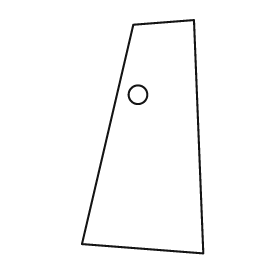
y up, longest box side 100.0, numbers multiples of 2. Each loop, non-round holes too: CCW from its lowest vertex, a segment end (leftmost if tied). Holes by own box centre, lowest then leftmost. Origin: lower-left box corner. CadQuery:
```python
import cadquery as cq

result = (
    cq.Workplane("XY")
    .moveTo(52.0, 0.0)
    .lineTo(48.0, 100.0)
    .lineTo(22.0, 98.0)
    .lineTo(0.0, 4.0)
    .close()
    .moveTo(24.0, 68.0)
    .circle(4.0)
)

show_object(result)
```